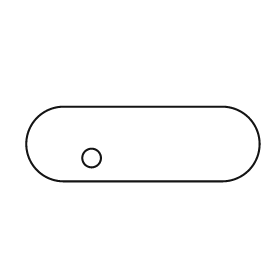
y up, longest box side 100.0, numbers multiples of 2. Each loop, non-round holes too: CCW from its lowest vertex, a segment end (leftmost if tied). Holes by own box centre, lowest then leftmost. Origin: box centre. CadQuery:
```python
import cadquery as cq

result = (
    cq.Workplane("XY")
    .moveTo(-34.0, -16.0)
    .lineTo(34.0, -16.0)
    .threePointArc((50.0, 0.0), (34.0, 16.0))
    .lineTo(-34.0, 16.0)
    .threePointArc((-50.0, 0.0), (-34.0, -16.0))
    .close()
    .moveTo(-22.0, -6.0)
    .circle(4.0)
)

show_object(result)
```